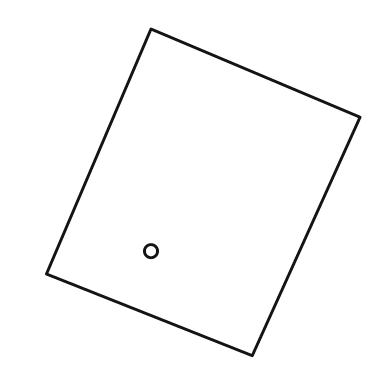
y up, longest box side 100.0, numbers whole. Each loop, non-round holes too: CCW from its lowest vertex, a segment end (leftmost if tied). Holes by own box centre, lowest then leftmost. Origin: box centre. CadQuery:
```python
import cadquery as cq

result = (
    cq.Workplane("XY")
    .moveTo(15.0, -50.0)
    .lineTo(48.0, 23.0)
    .lineTo(-16.0, 50.0)
    .lineTo(-48.0, -25.0)
    .close()
    .moveTo(-16.0, -18.0)
    .circle(2.0)
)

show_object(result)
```